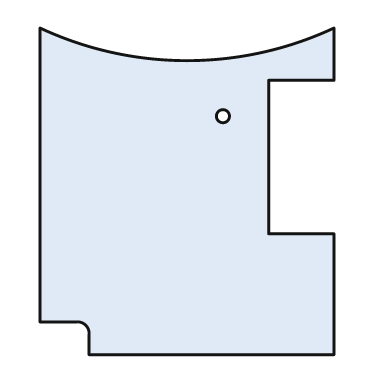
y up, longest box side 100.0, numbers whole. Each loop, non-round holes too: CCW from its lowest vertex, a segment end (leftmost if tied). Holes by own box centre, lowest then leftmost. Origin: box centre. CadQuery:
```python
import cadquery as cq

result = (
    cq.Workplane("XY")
    .moveTo(-30.0, -50.0)
    .lineTo(45.0, -50.0)
    .lineTo(45.0, -13.0)
    .lineTo(25.0, -13.0)
    .lineTo(25.0, 34.0)
    .lineTo(45.0, 34.0)
    .lineTo(45.0, 50.0)
    .threePointArc((0.0, 40.0), (-45.0, 50.0))
    .lineTo(-45.0, -40.0)
    .lineTo(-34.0, -40.0)
    .threePointArc((-31.0, -41.0), (-30.0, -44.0))
    .close()
    .moveTo(11.0, 23.0)
    .circle(2.0)
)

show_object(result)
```